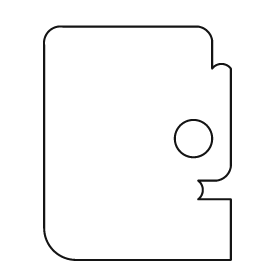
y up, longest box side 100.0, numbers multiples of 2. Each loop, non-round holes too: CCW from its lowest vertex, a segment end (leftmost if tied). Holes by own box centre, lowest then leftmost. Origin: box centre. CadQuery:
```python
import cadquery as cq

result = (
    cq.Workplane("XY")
    .moveTo(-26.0, -50.0)
    .lineTo(40.0, -50.0)
    .lineTo(40.0, -24.0)
    .lineTo(26.0, -24.0)
    .threePointArc((28.0, -20.0), (26.0, -16.0))
    .lineTo(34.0, -16.0)
    .threePointArc((38.0, -14.0), (40.0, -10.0))
    .lineTo(40.0, 32.0)
    .threePointArc((36.0, 34.0), (32.0, 32.0))
    .lineTo(32.0, 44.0)
    .threePointArc((30.0, 48.0), (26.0, 50.0))
    .lineTo(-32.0, 50.0)
    .threePointArc((-38.0, 48.0), (-40.0, 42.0))
    .lineTo(-40.0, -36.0)
    .threePointArc((-36.0, -46.0), (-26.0, -50.0))
    .close()
    .moveTo(24.0, 2.0)
    .circle(8.0)
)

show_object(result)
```